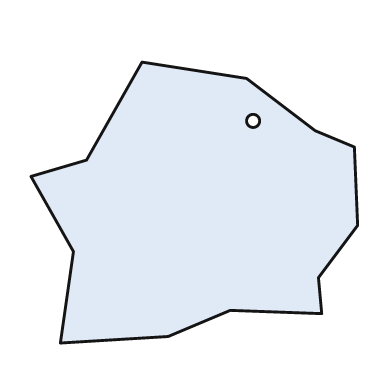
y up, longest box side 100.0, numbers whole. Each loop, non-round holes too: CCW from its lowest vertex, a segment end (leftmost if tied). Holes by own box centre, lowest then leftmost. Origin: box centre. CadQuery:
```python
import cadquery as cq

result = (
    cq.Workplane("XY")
    .moveTo(-41.0, -43.0)
    .lineTo(-8.0, -41.0)
    .lineTo(11.0, -33.0)
    .lineTo(39.0, -34.0)
    .lineTo(38.0, -23.0)
    .lineTo(50.0, -7.0)
    .lineTo(49.0, 17.0)
    .lineTo(37.0, 22.0)
    .lineTo(16.0, 38.0)
    .lineTo(-16.0, 43.0)
    .lineTo(-33.0, 13.0)
    .lineTo(-50.0, 8.0)
    .lineTo(-37.0, -15.0)
    .close()
    .moveTo(18.0, 25.0)
    .circle(2.0)
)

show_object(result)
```